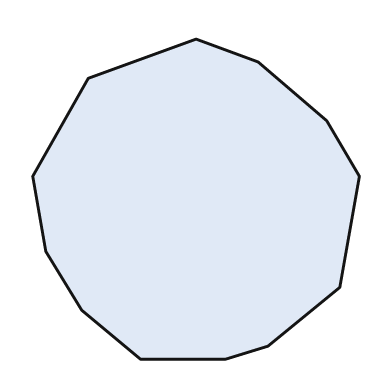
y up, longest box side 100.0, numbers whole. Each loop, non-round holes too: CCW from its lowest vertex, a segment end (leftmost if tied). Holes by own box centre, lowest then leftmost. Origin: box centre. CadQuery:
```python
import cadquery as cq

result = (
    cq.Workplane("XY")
    .moveTo(-17.0, -49.0)
    .lineTo(9.0, -49.0)
    .lineTo(22.0, -45.0)
    .lineTo(44.0, -27.0)
    .lineTo(50.0, 7.0)
    .lineTo(40.0, 24.0)
    .lineTo(19.0, 42.0)
    .lineTo(0.0, 49.0)
    .lineTo(-33.0, 37.0)
    .lineTo(-50.0, 7.0)
    .lineTo(-46.0, -16.0)
    .lineTo(-35.0, -34.0)
    .close()
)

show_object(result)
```